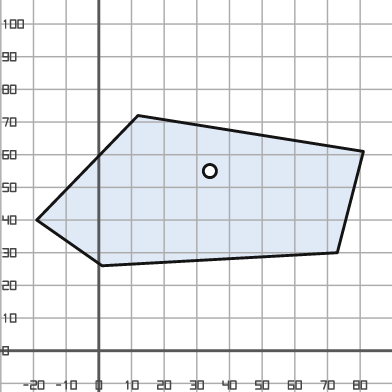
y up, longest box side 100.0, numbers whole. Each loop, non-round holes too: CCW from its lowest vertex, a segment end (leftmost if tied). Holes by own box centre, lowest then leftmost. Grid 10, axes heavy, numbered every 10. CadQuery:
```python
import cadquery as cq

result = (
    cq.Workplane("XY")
    .moveTo(1.0, 26.0)
    .lineTo(73.0, 30.0)
    .lineTo(81.0, 61.0)
    .lineTo(12.0, 72.0)
    .lineTo(-19.0, 40.0)
    .close()
    .moveTo(34.0, 55.0)
    .circle(2.0)
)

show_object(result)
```